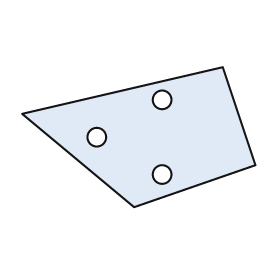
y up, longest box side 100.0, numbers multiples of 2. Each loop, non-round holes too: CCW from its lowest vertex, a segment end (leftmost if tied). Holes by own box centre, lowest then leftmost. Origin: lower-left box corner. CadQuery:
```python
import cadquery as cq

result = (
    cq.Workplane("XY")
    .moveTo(48.0, 0.0)
    .lineTo(100.0, 18.0)
    .lineTo(86.0, 60.0)
    .lineTo(0.0, 40.0)
    .close()
    .moveTo(60.0, 14.0)
    .circle(4.0)
    .moveTo(32.0, 30.0)
    .circle(4.0)
    .moveTo(60.0, 46.0)
    .circle(4.0)
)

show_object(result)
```